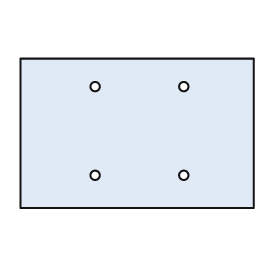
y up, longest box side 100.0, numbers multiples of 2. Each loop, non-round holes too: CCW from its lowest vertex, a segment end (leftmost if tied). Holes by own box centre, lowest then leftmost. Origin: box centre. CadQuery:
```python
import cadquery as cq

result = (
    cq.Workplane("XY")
    .moveTo(-50.0, -32.0)
    .lineTo(50.0, -32.0)
    .lineTo(50.0, 32.0)
    .lineTo(-50.0, 32.0)
    .close()
    .moveTo(-18.0, -18.0)
    .circle(2.0)
    .moveTo(20.0, -18.0)
    .circle(2.0)
    .moveTo(-18.0, 20.0)
    .circle(2.0)
    .moveTo(20.0, 20.0)
    .circle(2.0)
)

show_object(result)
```